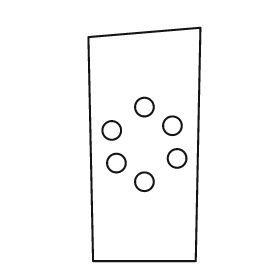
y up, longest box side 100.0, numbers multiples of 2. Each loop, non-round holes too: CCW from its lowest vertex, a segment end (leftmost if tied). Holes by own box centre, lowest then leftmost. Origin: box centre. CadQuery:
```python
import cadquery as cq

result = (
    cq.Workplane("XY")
    .moveTo(-22.0, -50.0)
    .lineTo(22.0, -50.0)
    .lineTo(24.0, 50.0)
    .lineTo(-24.0, 46.0)
    .close()
    .moveTo(0.0, -16.0)
    .circle(4.0)
    .moveTo(-12.0, -8.0)
    .circle(4.0)
    .moveTo(14.0, -6.0)
    .circle(4.0)
    .moveTo(-14.0, 6.0)
    .circle(4.0)
    .moveTo(12.0, 8.0)
    .circle(4.0)
    .moveTo(0.0, 16.0)
    .circle(4.0)
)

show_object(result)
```